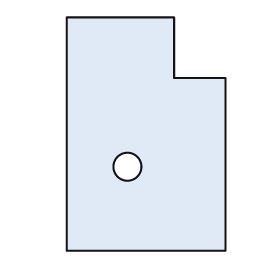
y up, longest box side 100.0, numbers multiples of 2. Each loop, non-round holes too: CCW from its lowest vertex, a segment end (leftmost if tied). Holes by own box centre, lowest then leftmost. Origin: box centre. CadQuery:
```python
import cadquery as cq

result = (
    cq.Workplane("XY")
    .moveTo(-34.0, -50.0)
    .lineTo(34.0, -50.0)
    .lineTo(34.0, 24.0)
    .lineTo(12.0, 24.0)
    .lineTo(12.0, 50.0)
    .lineTo(-34.0, 50.0)
    .close()
    .moveTo(-8.0, -14.0)
    .circle(6.0)
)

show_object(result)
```